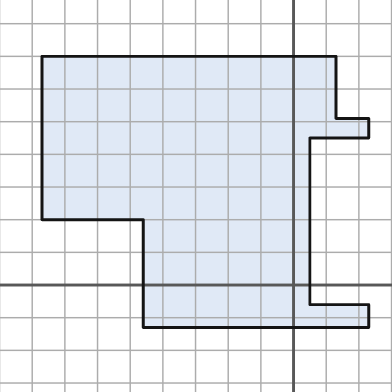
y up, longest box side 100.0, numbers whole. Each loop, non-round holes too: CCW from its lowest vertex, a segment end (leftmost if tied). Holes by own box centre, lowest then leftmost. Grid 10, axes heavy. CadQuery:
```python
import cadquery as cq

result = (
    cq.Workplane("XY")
    .moveTo(-46.0, -13.0)
    .lineTo(23.0, -13.0)
    .lineTo(23.0, -6.0)
    .lineTo(5.0, -6.0)
    .lineTo(5.0, 45.0)
    .lineTo(23.0, 45.0)
    .lineTo(23.0, 51.0)
    .lineTo(13.0, 51.0)
    .lineTo(13.0, 70.0)
    .lineTo(-77.0, 70.0)
    .lineTo(-77.0, 20.0)
    .lineTo(-46.0, 20.0)
    .close()
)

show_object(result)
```